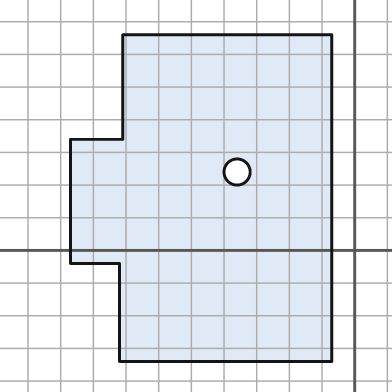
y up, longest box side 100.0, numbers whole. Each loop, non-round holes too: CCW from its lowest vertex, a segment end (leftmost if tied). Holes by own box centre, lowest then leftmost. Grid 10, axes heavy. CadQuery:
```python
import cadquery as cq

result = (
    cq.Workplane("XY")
    .moveTo(-72.0, -34.0)
    .lineTo(-7.0, -34.0)
    .lineTo(-7.0, 66.0)
    .lineTo(-71.0, 66.0)
    .lineTo(-71.0, 34.0)
    .lineTo(-87.0, 34.0)
    .lineTo(-87.0, -4.0)
    .lineTo(-72.0, -4.0)
    .close()
    .moveTo(-36.0, 24.0)
    .circle(4.0)
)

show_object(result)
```